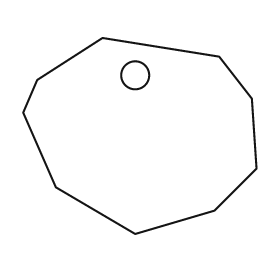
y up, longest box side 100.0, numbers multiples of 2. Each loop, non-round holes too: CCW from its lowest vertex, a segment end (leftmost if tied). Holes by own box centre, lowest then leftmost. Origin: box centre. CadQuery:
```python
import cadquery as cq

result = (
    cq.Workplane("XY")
    .moveTo(-2.0, -42.0)
    .lineTo(32.0, -32.0)
    .lineTo(50.0, -14.0)
    .lineTo(48.0, 16.0)
    .lineTo(34.0, 34.0)
    .lineTo(-16.0, 42.0)
    .lineTo(-44.0, 24.0)
    .lineTo(-50.0, 10.0)
    .lineTo(-36.0, -22.0)
    .close()
    .moveTo(-2.0, 26.0)
    .circle(6.0)
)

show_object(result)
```